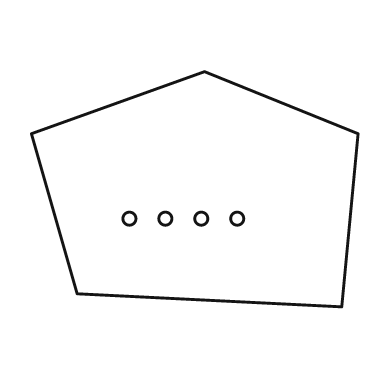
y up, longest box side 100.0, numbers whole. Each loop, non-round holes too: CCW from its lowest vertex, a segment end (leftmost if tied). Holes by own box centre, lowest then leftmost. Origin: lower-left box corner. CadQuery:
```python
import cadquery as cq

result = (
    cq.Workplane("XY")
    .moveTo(95.0, 0.0)
    .lineTo(100.0, 53.0)
    .lineTo(53.0, 72.0)
    .lineTo(0.0, 53.0)
    .lineTo(14.0, 4.0)
    .close()
    .moveTo(30.0, 27.0)
    .circle(2.0)
    .moveTo(41.0, 27.0)
    .circle(2.0)
    .moveTo(52.0, 27.0)
    .circle(2.0)
    .moveTo(63.0, 27.0)
    .circle(2.0)
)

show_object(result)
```